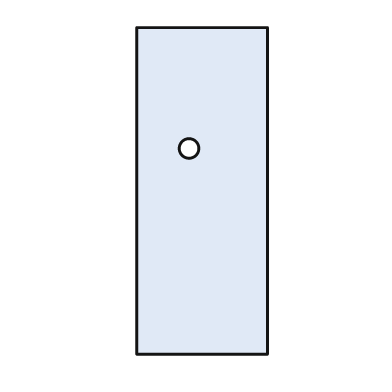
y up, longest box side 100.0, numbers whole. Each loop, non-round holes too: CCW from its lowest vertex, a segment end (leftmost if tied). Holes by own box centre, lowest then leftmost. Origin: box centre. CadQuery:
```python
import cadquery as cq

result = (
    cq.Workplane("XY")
    .moveTo(-20.0, -50.0)
    .lineTo(20.0, -50.0)
    .lineTo(20.0, 50.0)
    .lineTo(-20.0, 50.0)
    .close()
    .moveTo(-4.0, 13.0)
    .circle(3.0)
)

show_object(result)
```